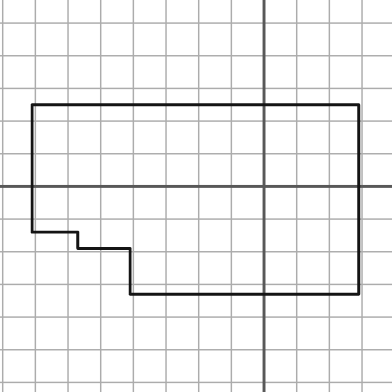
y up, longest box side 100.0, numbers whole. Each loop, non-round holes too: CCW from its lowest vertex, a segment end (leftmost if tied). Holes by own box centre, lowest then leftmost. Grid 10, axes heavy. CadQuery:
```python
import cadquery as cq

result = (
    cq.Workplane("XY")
    .moveTo(-41.0, -33.0)
    .lineTo(29.0, -33.0)
    .lineTo(29.0, 25.0)
    .lineTo(-71.0, 25.0)
    .lineTo(-71.0, -14.0)
    .lineTo(-57.0, -14.0)
    .lineTo(-57.0, -19.0)
    .lineTo(-41.0, -19.0)
    .close()
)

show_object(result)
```